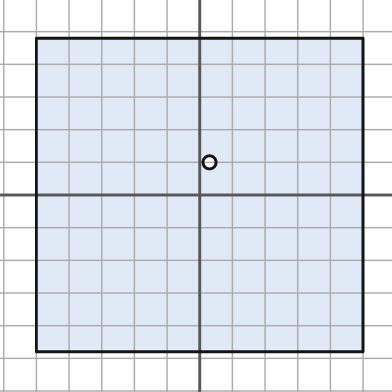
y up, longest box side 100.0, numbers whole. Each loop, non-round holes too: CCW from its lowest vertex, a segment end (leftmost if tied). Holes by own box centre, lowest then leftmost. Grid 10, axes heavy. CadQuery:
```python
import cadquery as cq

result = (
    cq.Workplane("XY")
    .moveTo(-50.0, -48.0)
    .lineTo(50.0, -48.0)
    .lineTo(50.0, 48.0)
    .lineTo(-50.0, 48.0)
    .close()
    .moveTo(3.0, 10.0)
    .circle(2.0)
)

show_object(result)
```